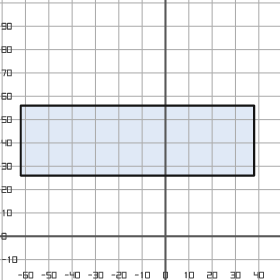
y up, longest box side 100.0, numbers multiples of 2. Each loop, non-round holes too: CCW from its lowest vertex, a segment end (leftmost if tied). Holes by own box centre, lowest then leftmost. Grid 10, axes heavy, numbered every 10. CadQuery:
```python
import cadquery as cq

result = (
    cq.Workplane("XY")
    .moveTo(-62.0, 26.0)
    .lineTo(38.0, 26.0)
    .lineTo(38.0, 56.0)
    .lineTo(-62.0, 56.0)
    .close()
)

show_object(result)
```